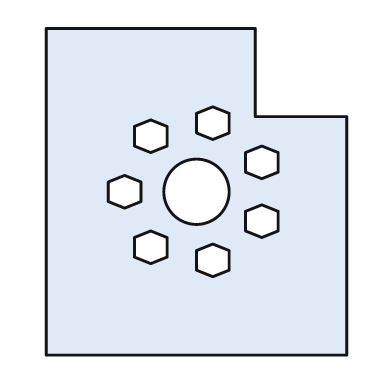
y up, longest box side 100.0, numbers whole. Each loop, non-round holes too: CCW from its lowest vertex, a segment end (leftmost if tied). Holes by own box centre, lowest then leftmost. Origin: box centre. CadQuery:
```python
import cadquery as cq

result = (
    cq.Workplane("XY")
    .moveTo(-46.0, -50.0)
    .lineTo(46.0, -50.0)
    .lineTo(46.0, 23.0)
    .lineTo(18.0, 23.0)
    .lineTo(18.0, 50.0)
    .lineTo(-46.0, 50.0)
    .close()
    .moveTo(5.0, -26.0)
    .lineTo(10.0, -24.0)
    .lineTo(10.0, -18.0)
    .lineTo(5.0, -16.0)
    .lineTo(0.0, -18.0)
    .lineTo(0.0, -24.0)
    .close()
    .moveTo(-14.0, -22.0)
    .lineTo(-9.0, -20.0)
    .lineTo(-9.0, -14.0)
    .lineTo(-14.0, -12.0)
    .lineTo(-19.0, -14.0)
    .lineTo(-19.0, -20.0)
    .close()
    .moveTo(20.0, -14.0)
    .lineTo(25.0, -12.0)
    .lineTo(25.0, -6.0)
    .lineTo(20.0, -4.0)
    .lineTo(15.0, -6.0)
    .lineTo(15.0, -12.0)
    .close()
    .moveTo(-22.0, -5.0)
    .lineTo(-17.0, -3.0)
    .lineTo(-17.0, 3.0)
    .lineTo(-22.0, 5.0)
    .lineTo(-27.0, 3.0)
    .lineTo(-27.0, -3.0)
    .close()
    .moveTo(0.0, 0.0)
    .circle(10.0)
    .moveTo(20.0, 4.0)
    .lineTo(25.0, 6.0)
    .lineTo(25.0, 12.0)
    .lineTo(20.0, 14.0)
    .lineTo(15.0, 12.0)
    .lineTo(15.0, 6.0)
    .close()
    .moveTo(-14.0, 12.0)
    .lineTo(-9.0, 14.0)
    .lineTo(-9.0, 20.0)
    .lineTo(-14.0, 22.0)
    .lineTo(-19.0, 20.0)
    .lineTo(-19.0, 14.0)
    .close()
    .moveTo(5.0, 16.0)
    .lineTo(10.0, 18.0)
    .lineTo(10.0, 24.0)
    .lineTo(5.0, 26.0)
    .lineTo(0.0, 24.0)
    .lineTo(0.0, 18.0)
    .close()
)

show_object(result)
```